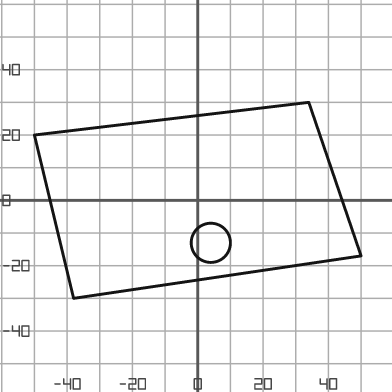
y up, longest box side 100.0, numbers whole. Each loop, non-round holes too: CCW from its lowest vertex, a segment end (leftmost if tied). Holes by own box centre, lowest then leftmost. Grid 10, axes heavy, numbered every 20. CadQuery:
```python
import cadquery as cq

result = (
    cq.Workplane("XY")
    .moveTo(-38.0, -30.0)
    .lineTo(50.0, -17.0)
    .lineTo(34.0, 30.0)
    .lineTo(-50.0, 20.0)
    .close()
    .moveTo(4.0, -13.0)
    .circle(6.0)
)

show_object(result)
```